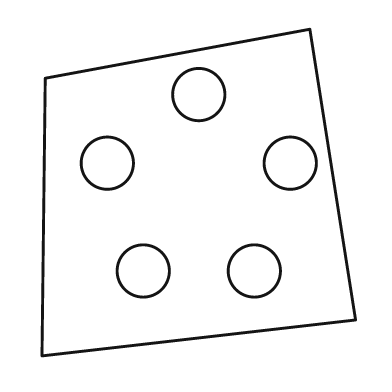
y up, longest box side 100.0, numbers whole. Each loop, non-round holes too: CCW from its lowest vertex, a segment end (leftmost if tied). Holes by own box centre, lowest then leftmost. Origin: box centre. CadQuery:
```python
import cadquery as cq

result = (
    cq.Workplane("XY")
    .moveTo(-48.0, -50.0)
    .lineTo(48.0, -39.0)
    .lineTo(34.0, 50.0)
    .lineTo(-47.0, 35.0)
    .close()
    .moveTo(-17.0, -24.0)
    .circle(8.0)
    .moveTo(17.0, -24.0)
    .circle(8.0)
    .moveTo(-28.0, 9.0)
    .circle(8.0)
    .moveTo(28.0, 9.0)
    .circle(8.0)
    .moveTo(0.0, 30.0)
    .circle(8.0)
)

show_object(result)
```